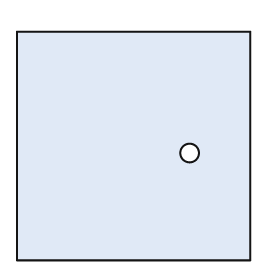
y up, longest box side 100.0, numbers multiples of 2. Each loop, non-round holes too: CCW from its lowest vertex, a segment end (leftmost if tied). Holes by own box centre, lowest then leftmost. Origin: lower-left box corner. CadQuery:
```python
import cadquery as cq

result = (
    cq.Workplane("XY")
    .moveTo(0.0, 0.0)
    .lineTo(100.0, 0.0)
    .lineTo(100.0, 98.0)
    .lineTo(0.0, 98.0)
    .close()
    .moveTo(74.0, 46.0)
    .circle(4.0)
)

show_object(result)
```